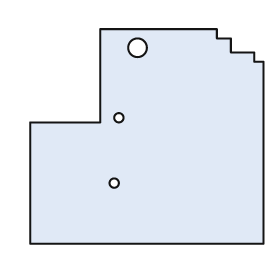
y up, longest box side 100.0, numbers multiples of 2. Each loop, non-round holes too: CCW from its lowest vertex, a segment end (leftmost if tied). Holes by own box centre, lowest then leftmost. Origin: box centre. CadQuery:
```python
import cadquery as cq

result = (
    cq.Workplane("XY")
    .moveTo(-50.0, -46.0)
    .lineTo(50.0, -46.0)
    .lineTo(50.0, 32.0)
    .lineTo(46.0, 32.0)
    .lineTo(46.0, 36.0)
    .lineTo(36.0, 36.0)
    .lineTo(36.0, 42.0)
    .lineTo(30.0, 42.0)
    .lineTo(30.0, 46.0)
    .lineTo(-20.0, 46.0)
    .lineTo(-20.0, 6.0)
    .lineTo(-50.0, 6.0)
    .close()
    .moveTo(-14.0, -20.0)
    .circle(2.0)
    .moveTo(-12.0, 8.0)
    .circle(2.0)
    .moveTo(-4.0, 38.0)
    .circle(4.0)
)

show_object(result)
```